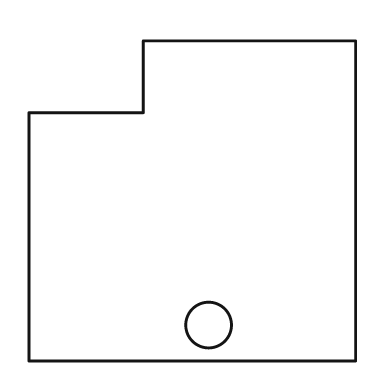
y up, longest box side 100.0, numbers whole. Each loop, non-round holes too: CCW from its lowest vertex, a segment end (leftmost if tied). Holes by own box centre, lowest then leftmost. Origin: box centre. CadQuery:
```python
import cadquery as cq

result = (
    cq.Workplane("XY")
    .moveTo(-50.0, -49.0)
    .lineTo(50.0, -49.0)
    .lineTo(50.0, 49.0)
    .lineTo(-15.0, 49.0)
    .lineTo(-15.0, 27.0)
    .lineTo(-50.0, 27.0)
    .close()
    .moveTo(5.0, -38.0)
    .circle(7.0)
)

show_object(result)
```